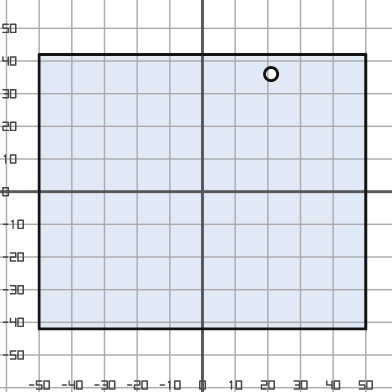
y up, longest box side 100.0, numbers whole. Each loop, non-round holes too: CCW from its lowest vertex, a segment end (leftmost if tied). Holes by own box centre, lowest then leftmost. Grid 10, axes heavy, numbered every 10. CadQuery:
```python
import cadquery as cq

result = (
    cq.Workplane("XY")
    .moveTo(-50.0, -42.0)
    .lineTo(50.0, -42.0)
    .lineTo(50.0, 42.0)
    .lineTo(-50.0, 42.0)
    .close()
    .moveTo(21.0, 36.0)
    .circle(2.0)
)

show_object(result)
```